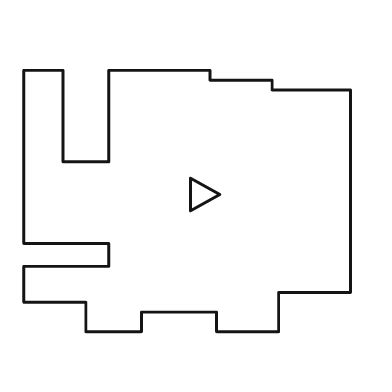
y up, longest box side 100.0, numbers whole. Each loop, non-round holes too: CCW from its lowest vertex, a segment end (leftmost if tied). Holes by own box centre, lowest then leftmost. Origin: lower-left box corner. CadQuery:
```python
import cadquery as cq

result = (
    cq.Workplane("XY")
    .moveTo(19.0, 0.0)
    .lineTo(36.0, 0.0)
    .lineTo(36.0, 6.0)
    .lineTo(59.0, 6.0)
    .lineTo(59.0, 0.0)
    .lineTo(78.0, 0.0)
    .lineTo(78.0, 12.0)
    .lineTo(100.0, 12.0)
    .lineTo(100.0, 74.0)
    .lineTo(76.0, 74.0)
    .lineTo(76.0, 77.0)
    .lineTo(57.0, 77.0)
    .lineTo(57.0, 80.0)
    .lineTo(26.0, 80.0)
    .lineTo(26.0, 52.0)
    .lineTo(12.0, 52.0)
    .lineTo(12.0, 80.0)
    .lineTo(0.0, 80.0)
    .lineTo(0.0, 27.0)
    .lineTo(26.0, 27.0)
    .lineTo(26.0, 20.0)
    .lineTo(0.0, 20.0)
    .lineTo(0.0, 9.0)
    .lineTo(19.0, 9.0)
    .close()
    .moveTo(51.0, 37.0)
    .lineTo(60.0, 42.0)
    .lineTo(51.0, 47.0)
    .close()
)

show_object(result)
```